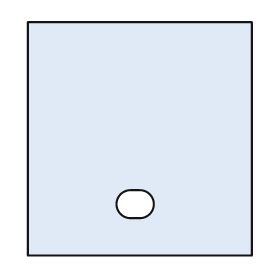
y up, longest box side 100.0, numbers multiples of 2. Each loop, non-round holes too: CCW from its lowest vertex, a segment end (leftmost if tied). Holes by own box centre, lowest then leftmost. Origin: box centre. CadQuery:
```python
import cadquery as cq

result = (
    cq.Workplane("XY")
    .moveTo(-48.0, -50.0)
    .lineTo(48.0, -50.0)
    .lineTo(48.0, 50.0)
    .lineTo(-48.0, 50.0)
    .close()
    .moveTo(-4.0, -34.0)
    .lineTo(0.0, -34.0)
    .threePointArc((6.0, -28.0), (0.0, -22.0))
    .lineTo(-4.0, -22.0)
    .threePointArc((-10.0, -28.0), (-4.0, -34.0))
    .close()
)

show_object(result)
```